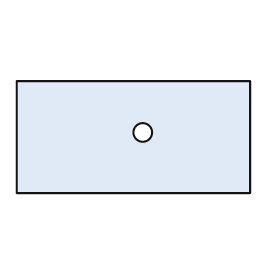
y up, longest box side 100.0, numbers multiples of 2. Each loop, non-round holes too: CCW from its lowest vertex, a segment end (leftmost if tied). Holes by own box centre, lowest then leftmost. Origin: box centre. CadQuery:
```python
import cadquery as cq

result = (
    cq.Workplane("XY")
    .moveTo(-50.0, -24.0)
    .lineTo(50.0, -24.0)
    .lineTo(50.0, 24.0)
    .lineTo(-50.0, 24.0)
    .close()
    .moveTo(4.0, 2.0)
    .circle(4.0)
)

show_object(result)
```